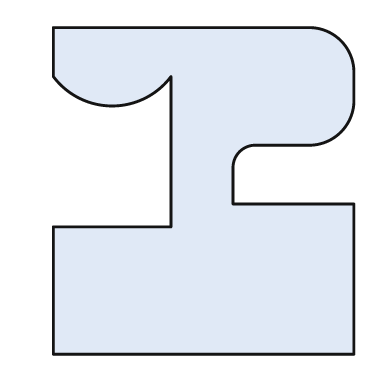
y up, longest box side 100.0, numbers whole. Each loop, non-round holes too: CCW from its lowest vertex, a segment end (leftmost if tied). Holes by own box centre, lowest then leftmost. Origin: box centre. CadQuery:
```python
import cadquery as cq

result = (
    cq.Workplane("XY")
    .moveTo(-46.0, -50.0)
    .lineTo(46.0, -50.0)
    .lineTo(46.0, -4.0)
    .lineTo(9.0, -4.0)
    .lineTo(9.0, 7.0)
    .threePointArc((11.0, 12.0), (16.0, 14.0))
    .lineTo(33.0, 14.0)
    .threePointArc((42.0, 18.0), (46.0, 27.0))
    .lineTo(46.0, 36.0)
    .threePointArc((42.0, 46.0), (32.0, 50.0))
    .lineTo(-46.0, 50.0)
    .lineTo(-46.0, 35.0)
    .threePointArc((-28.0, 26.0), (-10.0, 35.0))
    .lineTo(-10.0, -11.0)
    .lineTo(-46.0, -11.0)
    .close()
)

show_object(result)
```